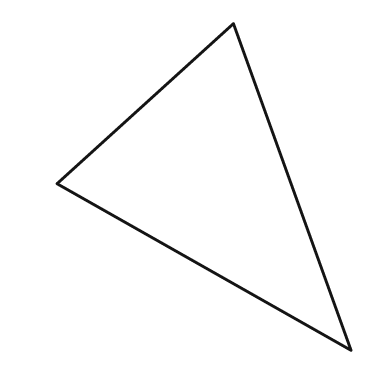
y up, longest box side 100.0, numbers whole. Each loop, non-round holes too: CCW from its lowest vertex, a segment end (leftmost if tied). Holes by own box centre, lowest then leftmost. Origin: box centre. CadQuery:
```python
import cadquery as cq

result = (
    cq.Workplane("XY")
    .moveTo(45.0, -50.0)
    .lineTo(9.0, 50.0)
    .lineTo(-45.0, 1.0)
    .close()
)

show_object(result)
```